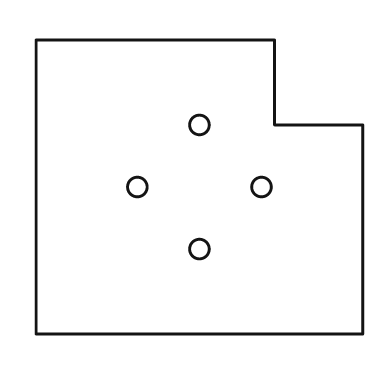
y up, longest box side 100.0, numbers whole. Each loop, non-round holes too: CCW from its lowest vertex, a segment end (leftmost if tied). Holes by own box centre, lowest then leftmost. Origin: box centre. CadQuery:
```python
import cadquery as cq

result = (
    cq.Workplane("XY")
    .moveTo(-50.0, -45.0)
    .lineTo(50.0, -45.0)
    .lineTo(50.0, 19.0)
    .lineTo(23.0, 19.0)
    .lineTo(23.0, 45.0)
    .lineTo(-50.0, 45.0)
    .close()
    .moveTo(0.0, -19.0)
    .circle(3.0)
    .moveTo(-19.0, 0.0)
    .circle(3.0)
    .moveTo(19.0, 0.0)
    .circle(3.0)
    .moveTo(0.0, 19.0)
    .circle(3.0)
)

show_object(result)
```